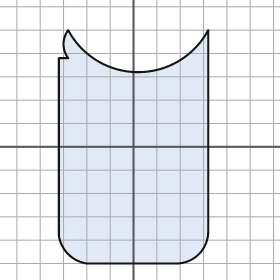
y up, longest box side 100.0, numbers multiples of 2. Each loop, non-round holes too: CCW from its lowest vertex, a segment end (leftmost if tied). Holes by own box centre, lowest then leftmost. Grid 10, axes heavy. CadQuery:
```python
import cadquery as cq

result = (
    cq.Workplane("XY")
    .moveTo(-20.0, -50.0)
    .lineTo(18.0, -50.0)
    .threePointArc((28.0, -46.0), (32.0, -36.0))
    .lineTo(32.0, 50.0)
    .threePointArc((2.0, 32.0), (-28.0, 50.0))
    .threePointArc((-30.0, 44.0), (-28.0, 38.0))
    .lineTo(-32.0, 38.0)
    .lineTo(-32.0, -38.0)
    .threePointArc((-28.0, -46.0), (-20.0, -50.0))
    .close()
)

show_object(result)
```